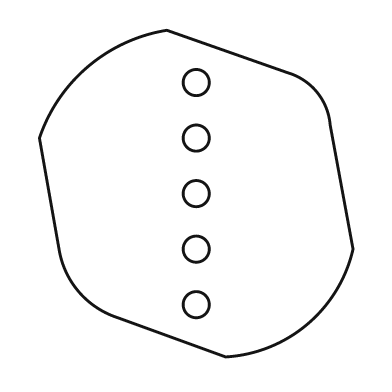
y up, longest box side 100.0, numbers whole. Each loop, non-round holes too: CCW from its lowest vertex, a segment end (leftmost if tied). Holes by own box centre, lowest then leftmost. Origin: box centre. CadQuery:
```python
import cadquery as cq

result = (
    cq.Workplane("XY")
    .moveTo(9.0, -50.0)
    .threePointArc((34.0, -40.0), (48.0, -17.0))
    .lineTo(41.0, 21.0)
    .threePointArc((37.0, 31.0), (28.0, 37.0))
    .lineTo(-9.0, 50.0)
    .threePointArc((-33.0, 39.0), (-48.0, 17.0))
    .lineTo(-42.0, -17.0)
    .threePointArc((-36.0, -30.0), (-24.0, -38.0))
    .close()
    .moveTo(0.0, -34.0)
    .circle(4.0)
    .moveTo(0.0, -17.0)
    .circle(4.0)
    .moveTo(0.0, 0.0)
    .circle(4.0)
    .moveTo(0.0, 17.0)
    .circle(4.0)
    .moveTo(0.0, 34.0)
    .circle(4.0)
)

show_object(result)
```